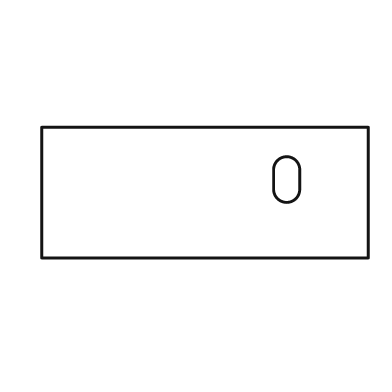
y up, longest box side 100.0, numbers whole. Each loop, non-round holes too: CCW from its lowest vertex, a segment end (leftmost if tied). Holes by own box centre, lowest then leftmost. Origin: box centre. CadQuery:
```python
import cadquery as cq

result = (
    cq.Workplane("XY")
    .moveTo(-50.0, -20.0)
    .lineTo(50.0, -20.0)
    .lineTo(50.0, 20.0)
    .lineTo(-50.0, 20.0)
    .close()
    .moveTo(21.0, 1.0)
    .threePointArc((25.0, -3.0), (29.0, 1.0))
    .lineTo(29.0, 7.0)
    .threePointArc((25.0, 11.0), (21.0, 7.0))
    .close()
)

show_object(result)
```